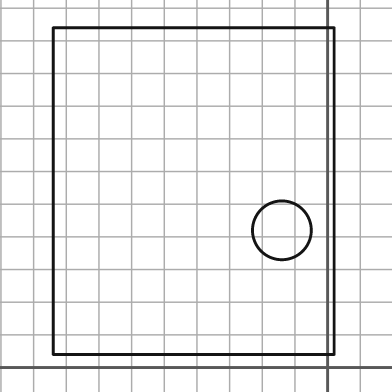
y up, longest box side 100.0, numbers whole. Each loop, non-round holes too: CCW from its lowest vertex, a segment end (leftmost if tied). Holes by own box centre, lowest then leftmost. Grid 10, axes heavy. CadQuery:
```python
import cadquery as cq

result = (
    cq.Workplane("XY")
    .moveTo(-84.0, 4.0)
    .lineTo(2.0, 4.0)
    .lineTo(2.0, 104.0)
    .lineTo(-84.0, 104.0)
    .close()
    .moveTo(-14.0, 42.0)
    .circle(9.0)
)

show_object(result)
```